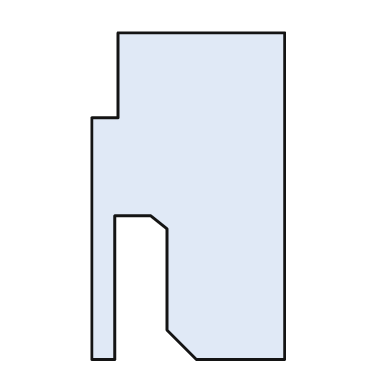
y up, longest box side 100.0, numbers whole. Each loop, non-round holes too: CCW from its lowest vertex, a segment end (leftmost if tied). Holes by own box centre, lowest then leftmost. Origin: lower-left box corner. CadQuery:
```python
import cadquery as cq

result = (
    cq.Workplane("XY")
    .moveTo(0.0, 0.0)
    .lineTo(7.0, 0.0)
    .lineTo(7.0, 44.0)
    .lineTo(18.0, 44.0)
    .lineTo(23.0, 40.0)
    .lineTo(23.0, 9.0)
    .lineTo(32.0, 0.0)
    .lineTo(59.0, 0.0)
    .lineTo(59.0, 100.0)
    .lineTo(8.0, 100.0)
    .lineTo(8.0, 74.0)
    .lineTo(0.0, 74.0)
    .close()
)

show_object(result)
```